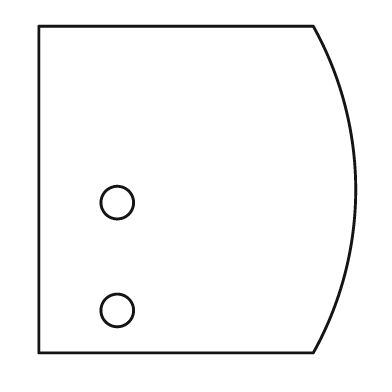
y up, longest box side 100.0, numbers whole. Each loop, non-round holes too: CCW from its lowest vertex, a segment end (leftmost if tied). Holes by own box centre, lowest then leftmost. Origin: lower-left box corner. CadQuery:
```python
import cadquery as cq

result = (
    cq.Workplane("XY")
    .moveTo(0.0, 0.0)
    .lineTo(84.0, 0.0)
    .threePointArc((97.0, 50.0), (84.0, 100.0))
    .lineTo(0.0, 100.0)
    .close()
    .moveTo(24.0, 13.0)
    .circle(5.0)
    .moveTo(24.0, 46.0)
    .circle(5.0)
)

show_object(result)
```